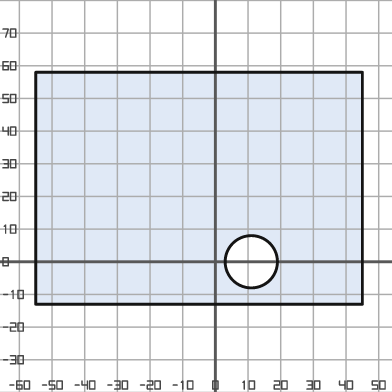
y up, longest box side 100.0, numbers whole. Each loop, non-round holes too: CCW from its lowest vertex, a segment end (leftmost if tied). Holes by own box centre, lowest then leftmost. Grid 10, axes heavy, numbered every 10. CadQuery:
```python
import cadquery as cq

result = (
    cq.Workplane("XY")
    .moveTo(-55.0, -13.0)
    .lineTo(45.0, -13.0)
    .lineTo(45.0, 58.0)
    .lineTo(-55.0, 58.0)
    .close()
    .moveTo(11.0, 0.0)
    .circle(8.0)
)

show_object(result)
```